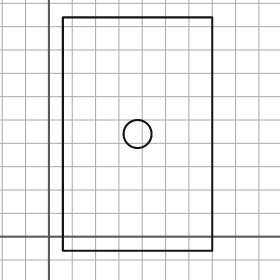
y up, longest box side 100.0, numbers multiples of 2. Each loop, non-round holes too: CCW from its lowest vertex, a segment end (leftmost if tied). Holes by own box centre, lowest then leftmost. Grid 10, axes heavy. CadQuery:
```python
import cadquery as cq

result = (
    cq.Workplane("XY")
    .moveTo(6.0, -6.0)
    .lineTo(70.0, -6.0)
    .lineTo(70.0, 94.0)
    .lineTo(6.0, 94.0)
    .close()
    .moveTo(38.0, 44.0)
    .circle(6.0)
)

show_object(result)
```